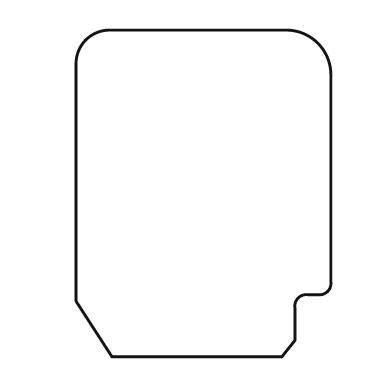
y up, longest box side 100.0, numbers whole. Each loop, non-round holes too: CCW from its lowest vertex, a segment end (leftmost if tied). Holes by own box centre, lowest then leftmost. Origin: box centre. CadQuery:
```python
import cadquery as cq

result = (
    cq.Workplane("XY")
    .moveTo(-28.0, -50.0)
    .lineTo(24.0, -50.0)
    .lineTo(28.0, -45.0)
    .lineTo(28.0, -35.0)
    .threePointArc((29.0, -32.0), (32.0, -31.0))
    .lineTo(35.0, -31.0)
    .threePointArc((38.0, -30.0), (39.0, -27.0))
    .lineTo(39.0, 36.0)
    .threePointArc((35.0, 46.0), (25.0, 50.0))
    .lineTo(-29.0, 50.0)
    .threePointArc((-36.0, 47.0), (-39.0, 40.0))
    .lineTo(-39.0, -33.0)
    .close()
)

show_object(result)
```